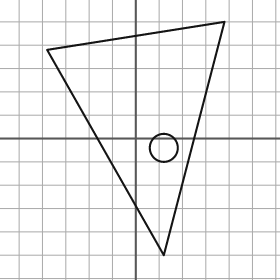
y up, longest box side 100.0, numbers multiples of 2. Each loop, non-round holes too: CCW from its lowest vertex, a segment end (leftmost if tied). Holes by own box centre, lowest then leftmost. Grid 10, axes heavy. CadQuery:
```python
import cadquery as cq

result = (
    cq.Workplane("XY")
    .moveTo(12.0, -50.0)
    .lineTo(38.0, 50.0)
    .lineTo(-38.0, 38.0)
    .close()
    .moveTo(12.0, -4.0)
    .circle(6.0)
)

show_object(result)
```